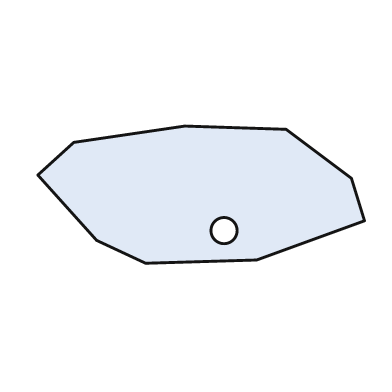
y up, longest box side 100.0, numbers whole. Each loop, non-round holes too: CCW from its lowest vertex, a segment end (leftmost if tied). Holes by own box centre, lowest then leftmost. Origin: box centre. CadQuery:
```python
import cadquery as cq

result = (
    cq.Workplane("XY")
    .moveTo(-17.0, -21.0)
    .lineTo(17.0, -20.0)
    .lineTo(50.0, -8.0)
    .lineTo(46.0, 5.0)
    .lineTo(26.0, 20.0)
    .lineTo(-5.0, 21.0)
    .lineTo(-39.0, 16.0)
    .lineTo(-50.0, 6.0)
    .lineTo(-32.0, -14.0)
    .close()
    .moveTo(7.0, -11.0)
    .circle(4.0)
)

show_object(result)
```